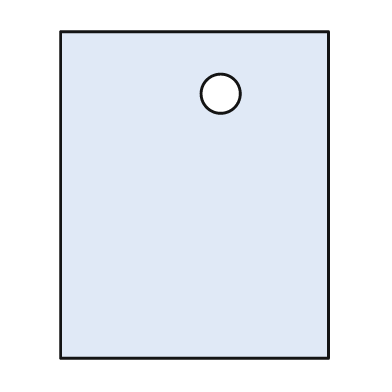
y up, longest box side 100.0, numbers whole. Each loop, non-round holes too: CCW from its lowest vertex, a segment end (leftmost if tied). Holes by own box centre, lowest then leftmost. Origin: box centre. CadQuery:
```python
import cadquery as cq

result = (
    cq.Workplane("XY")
    .moveTo(-41.0, -50.0)
    .lineTo(41.0, -50.0)
    .lineTo(41.0, 50.0)
    .lineTo(-41.0, 50.0)
    .close()
    .moveTo(8.0, 31.0)
    .circle(6.0)
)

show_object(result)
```